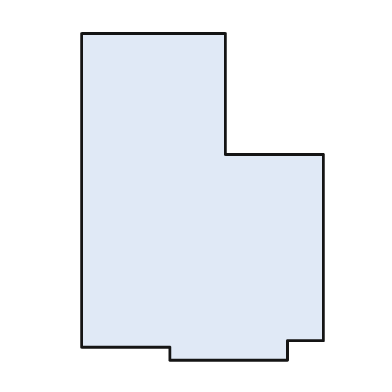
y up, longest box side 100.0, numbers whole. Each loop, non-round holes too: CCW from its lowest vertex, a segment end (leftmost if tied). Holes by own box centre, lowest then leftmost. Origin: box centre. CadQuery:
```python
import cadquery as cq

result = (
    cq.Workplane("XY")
    .moveTo(-10.0, -50.0)
    .lineTo(26.0, -50.0)
    .lineTo(26.0, -44.0)
    .lineTo(37.0, -44.0)
    .lineTo(37.0, 13.0)
    .lineTo(7.0, 13.0)
    .lineTo(7.0, 50.0)
    .lineTo(-37.0, 50.0)
    .lineTo(-37.0, -46.0)
    .lineTo(-10.0, -46.0)
    .close()
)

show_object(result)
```